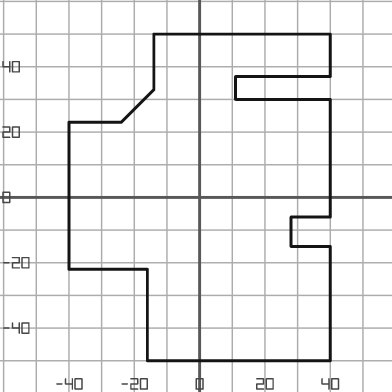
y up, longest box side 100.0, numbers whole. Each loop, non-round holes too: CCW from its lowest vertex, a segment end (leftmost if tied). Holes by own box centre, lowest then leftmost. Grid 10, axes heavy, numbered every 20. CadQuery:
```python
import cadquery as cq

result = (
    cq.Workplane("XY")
    .moveTo(-16.0, -50.0)
    .lineTo(40.0, -50.0)
    .lineTo(40.0, -15.0)
    .lineTo(28.0, -15.0)
    .lineTo(28.0, -6.0)
    .lineTo(40.0, -6.0)
    .lineTo(40.0, 30.0)
    .lineTo(11.0, 30.0)
    .lineTo(11.0, 37.0)
    .lineTo(40.0, 37.0)
    .lineTo(40.0, 50.0)
    .lineTo(-14.0, 50.0)
    .lineTo(-14.0, 33.0)
    .lineTo(-24.0, 23.0)
    .lineTo(-40.0, 23.0)
    .lineTo(-40.0, -22.0)
    .lineTo(-16.0, -22.0)
    .close()
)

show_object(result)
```